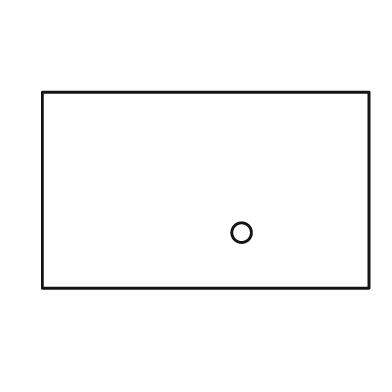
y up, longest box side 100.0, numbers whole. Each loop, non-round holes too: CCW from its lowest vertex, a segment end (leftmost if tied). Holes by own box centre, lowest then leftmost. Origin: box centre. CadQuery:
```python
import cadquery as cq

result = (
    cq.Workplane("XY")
    .moveTo(-50.0, -30.0)
    .lineTo(50.0, -30.0)
    .lineTo(50.0, 30.0)
    .lineTo(-50.0, 30.0)
    .close()
    .moveTo(11.0, -13.0)
    .circle(3.0)
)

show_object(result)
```